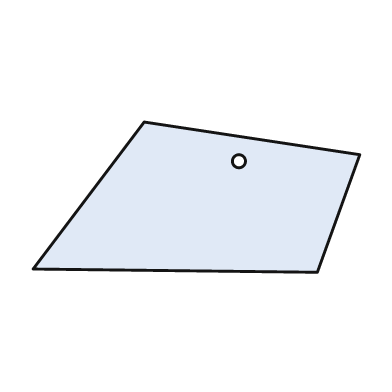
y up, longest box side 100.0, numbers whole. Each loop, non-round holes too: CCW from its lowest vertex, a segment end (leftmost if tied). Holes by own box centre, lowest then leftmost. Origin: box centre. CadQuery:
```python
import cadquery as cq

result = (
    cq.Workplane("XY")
    .moveTo(37.0, -23.0)
    .lineTo(50.0, 13.0)
    .lineTo(-16.0, 23.0)
    .lineTo(-50.0, -22.0)
    .close()
    .moveTo(13.0, 11.0)
    .circle(2.0)
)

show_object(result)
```